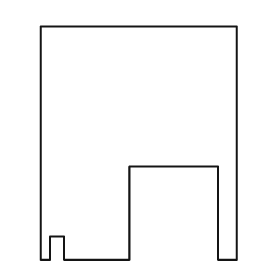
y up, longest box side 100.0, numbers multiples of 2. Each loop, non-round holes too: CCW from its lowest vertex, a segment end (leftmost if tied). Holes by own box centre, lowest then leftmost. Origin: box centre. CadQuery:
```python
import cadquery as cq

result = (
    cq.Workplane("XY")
    .moveTo(-42.0, -50.0)
    .lineTo(-38.0, -50.0)
    .lineTo(-38.0, -40.0)
    .lineTo(-32.0, -40.0)
    .lineTo(-32.0, -50.0)
    .lineTo(-4.0, -50.0)
    .lineTo(-4.0, -10.0)
    .lineTo(34.0, -10.0)
    .lineTo(34.0, -50.0)
    .lineTo(42.0, -50.0)
    .lineTo(42.0, 50.0)
    .lineTo(-42.0, 50.0)
    .close()
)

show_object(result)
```